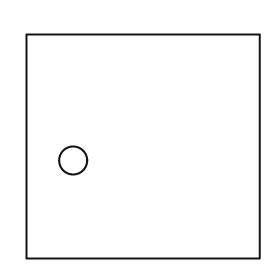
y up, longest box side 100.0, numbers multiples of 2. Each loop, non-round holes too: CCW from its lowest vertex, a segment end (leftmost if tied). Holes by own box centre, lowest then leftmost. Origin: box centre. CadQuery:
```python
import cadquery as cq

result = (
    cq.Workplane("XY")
    .moveTo(-50.0, -48.0)
    .lineTo(50.0, -48.0)
    .lineTo(50.0, 48.0)
    .lineTo(-50.0, 48.0)
    .close()
    .moveTo(-30.0, -6.0)
    .circle(6.0)
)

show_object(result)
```